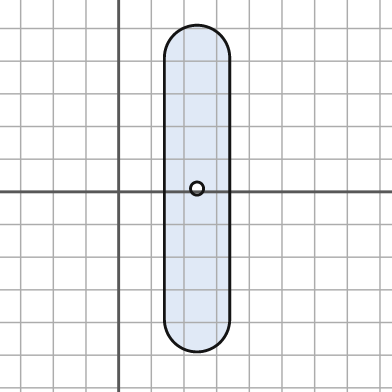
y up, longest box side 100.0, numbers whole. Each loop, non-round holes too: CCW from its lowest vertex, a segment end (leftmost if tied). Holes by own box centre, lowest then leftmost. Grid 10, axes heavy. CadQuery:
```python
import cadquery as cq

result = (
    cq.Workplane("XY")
    .moveTo(14.0, -39.0)
    .threePointArc((24.0, -49.0), (34.0, -39.0))
    .lineTo(34.0, 41.0)
    .threePointArc((24.0, 51.0), (14.0, 41.0))
    .close()
    .moveTo(24.0, 1.0)
    .circle(2.0)
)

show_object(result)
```